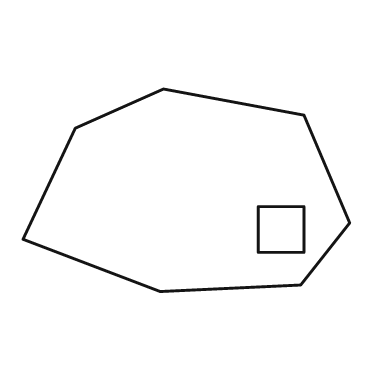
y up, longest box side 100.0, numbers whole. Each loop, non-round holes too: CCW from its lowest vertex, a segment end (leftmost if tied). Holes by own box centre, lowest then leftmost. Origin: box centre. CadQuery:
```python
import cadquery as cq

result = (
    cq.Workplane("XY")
    .moveTo(-8.0, -31.0)
    .lineTo(35.0, -29.0)
    .lineTo(50.0, -10.0)
    .lineTo(36.0, 23.0)
    .lineTo(-7.0, 31.0)
    .lineTo(-34.0, 19.0)
    .lineTo(-50.0, -15.0)
    .close()
    .moveTo(22.0, -19.0)
    .lineTo(36.0, -19.0)
    .lineTo(36.0, -5.0)
    .lineTo(22.0, -5.0)
    .close()
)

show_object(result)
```